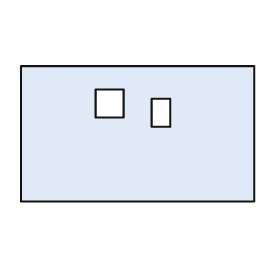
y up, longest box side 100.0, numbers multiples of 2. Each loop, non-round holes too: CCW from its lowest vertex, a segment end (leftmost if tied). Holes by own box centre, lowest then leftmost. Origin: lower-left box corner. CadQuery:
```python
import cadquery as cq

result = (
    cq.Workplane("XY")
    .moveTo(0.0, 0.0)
    .lineTo(100.0, 0.0)
    .lineTo(100.0, 58.0)
    .lineTo(0.0, 58.0)
    .close()
    .moveTo(56.0, 32.0)
    .lineTo(64.0, 32.0)
    .lineTo(64.0, 44.0)
    .lineTo(56.0, 44.0)
    .close()
    .moveTo(32.0, 36.0)
    .lineTo(44.0, 36.0)
    .lineTo(44.0, 48.0)
    .lineTo(32.0, 48.0)
    .close()
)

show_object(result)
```